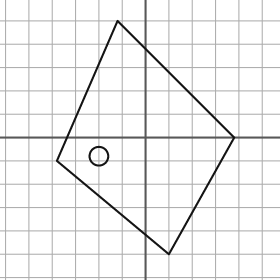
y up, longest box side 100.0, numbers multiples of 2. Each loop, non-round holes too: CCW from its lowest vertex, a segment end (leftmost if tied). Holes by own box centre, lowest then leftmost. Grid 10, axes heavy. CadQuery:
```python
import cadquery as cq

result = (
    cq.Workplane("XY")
    .moveTo(10.0, -50.0)
    .lineTo(38.0, 0.0)
    .lineTo(-12.0, 50.0)
    .lineTo(-38.0, -10.0)
    .close()
    .moveTo(-20.0, -8.0)
    .circle(4.0)
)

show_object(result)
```